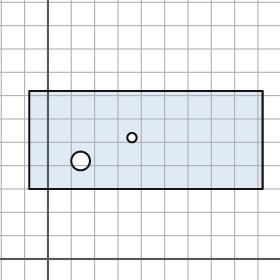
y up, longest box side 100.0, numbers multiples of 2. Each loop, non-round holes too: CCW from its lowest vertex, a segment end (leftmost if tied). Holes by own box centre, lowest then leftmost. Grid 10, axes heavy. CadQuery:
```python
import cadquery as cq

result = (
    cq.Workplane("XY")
    .moveTo(-8.0, 30.0)
    .lineTo(92.0, 30.0)
    .lineTo(92.0, 72.0)
    .lineTo(-8.0, 72.0)
    .close()
    .moveTo(14.0, 42.0)
    .circle(4.0)
    .moveTo(36.0, 52.0)
    .circle(2.0)
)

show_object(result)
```